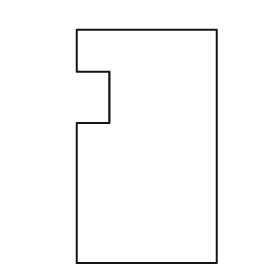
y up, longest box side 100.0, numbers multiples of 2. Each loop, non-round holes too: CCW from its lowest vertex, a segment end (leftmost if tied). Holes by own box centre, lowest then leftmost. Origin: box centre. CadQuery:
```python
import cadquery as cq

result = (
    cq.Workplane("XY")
    .moveTo(-30.0, -50.0)
    .lineTo(30.0, -50.0)
    .lineTo(30.0, 50.0)
    .lineTo(-30.0, 50.0)
    .lineTo(-30.0, 32.0)
    .lineTo(-16.0, 32.0)
    .lineTo(-16.0, 10.0)
    .lineTo(-30.0, 10.0)
    .close()
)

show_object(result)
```